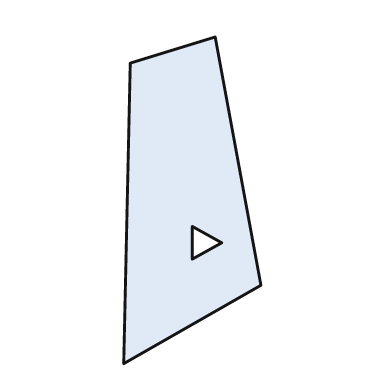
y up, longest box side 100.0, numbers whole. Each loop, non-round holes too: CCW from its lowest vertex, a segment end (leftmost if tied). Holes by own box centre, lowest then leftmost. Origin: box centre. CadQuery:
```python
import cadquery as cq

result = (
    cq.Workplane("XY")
    .moveTo(-21.0, -50.0)
    .lineTo(21.0, -26.0)
    .lineTo(7.0, 50.0)
    .lineTo(-19.0, 42.0)
    .close()
    .moveTo(0.0, -18.0)
    .lineTo(9.0, -13.0)
    .lineTo(0.0, -8.0)
    .close()
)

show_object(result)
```